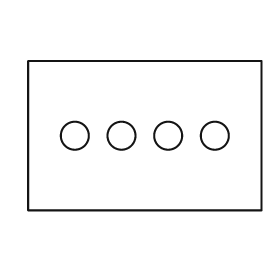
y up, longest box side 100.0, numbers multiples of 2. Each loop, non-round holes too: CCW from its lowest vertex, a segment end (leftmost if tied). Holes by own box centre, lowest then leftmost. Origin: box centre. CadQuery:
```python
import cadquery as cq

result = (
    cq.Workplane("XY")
    .moveTo(-50.0, -32.0)
    .lineTo(50.0, -32.0)
    .lineTo(50.0, 32.0)
    .lineTo(-50.0, 32.0)
    .close()
    .moveTo(-30.0, 0.0)
    .circle(6.0)
    .moveTo(-10.0, 0.0)
    .circle(6.0)
    .moveTo(10.0, 0.0)
    .circle(6.0)
    .moveTo(30.0, 0.0)
    .circle(6.0)
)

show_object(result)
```